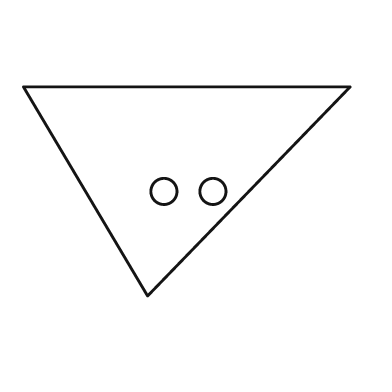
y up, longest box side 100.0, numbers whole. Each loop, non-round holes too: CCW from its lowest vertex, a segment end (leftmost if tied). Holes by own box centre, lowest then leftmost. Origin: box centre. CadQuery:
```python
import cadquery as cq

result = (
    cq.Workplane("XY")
    .moveTo(-12.0, -32.0)
    .lineTo(50.0, 32.0)
    .lineTo(-50.0, 32.0)
    .close()
    .moveTo(-7.0, 0.0)
    .circle(4.0)
    .moveTo(8.0, 0.0)
    .circle(4.0)
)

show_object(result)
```